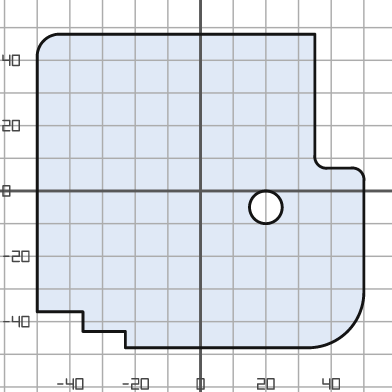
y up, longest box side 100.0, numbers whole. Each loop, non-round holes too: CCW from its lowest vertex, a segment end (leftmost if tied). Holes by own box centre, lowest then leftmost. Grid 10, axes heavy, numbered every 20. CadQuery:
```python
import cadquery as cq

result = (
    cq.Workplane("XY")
    .moveTo(-23.0, -48.0)
    .lineTo(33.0, -48.0)
    .threePointArc((45.0, -43.0), (50.0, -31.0))
    .lineTo(50.0, 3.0)
    .threePointArc((49.0, 6.0), (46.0, 7.0))
    .lineTo(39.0, 7.0)
    .threePointArc((36.0, 8.0), (35.0, 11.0))
    .lineTo(35.0, 48.0)
    .lineTo(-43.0, 48.0)
    .threePointArc((-48.0, 46.0), (-50.0, 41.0))
    .lineTo(-50.0, -37.0)
    .lineTo(-36.0, -37.0)
    .lineTo(-36.0, -43.0)
    .lineTo(-23.0, -43.0)
    .close()
    .moveTo(20.0, -5.0)
    .circle(5.0)
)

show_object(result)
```